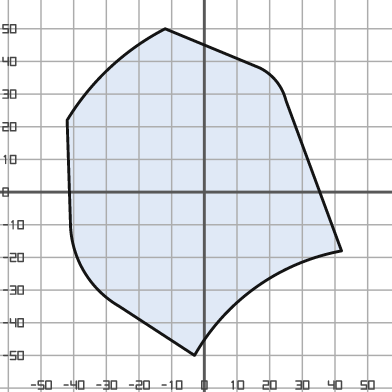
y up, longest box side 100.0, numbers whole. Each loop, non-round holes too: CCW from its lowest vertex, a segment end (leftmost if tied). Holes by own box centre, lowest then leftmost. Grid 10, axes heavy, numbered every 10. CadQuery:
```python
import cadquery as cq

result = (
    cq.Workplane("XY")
    .moveTo(-3.0, -50.0)
    .threePointArc((16.0, -29.0), (42.0, -18.0))
    .lineTo(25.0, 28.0)
    .threePointArc((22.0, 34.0), (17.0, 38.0))
    .lineTo(-12.0, 50.0)
    .threePointArc((-29.0, 38.0), (-42.0, 22.0))
    .lineTo(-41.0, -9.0)
    .threePointArc((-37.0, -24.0), (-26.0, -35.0))
    .close()
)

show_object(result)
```